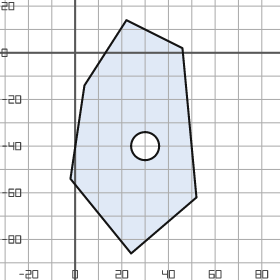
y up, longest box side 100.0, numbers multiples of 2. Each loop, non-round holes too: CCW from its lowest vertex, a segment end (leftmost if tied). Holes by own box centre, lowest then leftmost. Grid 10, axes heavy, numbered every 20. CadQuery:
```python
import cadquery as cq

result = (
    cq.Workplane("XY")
    .moveTo(24.0, -86.0)
    .lineTo(52.0, -62.0)
    .lineTo(46.0, 2.0)
    .lineTo(22.0, 14.0)
    .lineTo(4.0, -14.0)
    .lineTo(-2.0, -54.0)
    .close()
    .moveTo(30.0, -40.0)
    .circle(6.0)
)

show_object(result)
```